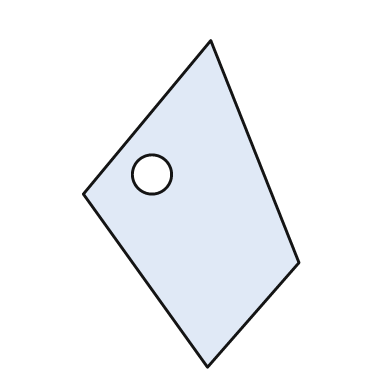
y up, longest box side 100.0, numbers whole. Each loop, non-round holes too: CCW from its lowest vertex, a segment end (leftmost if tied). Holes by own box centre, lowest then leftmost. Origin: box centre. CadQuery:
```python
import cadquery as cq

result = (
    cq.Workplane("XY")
    .moveTo(5.0, -50.0)
    .lineTo(33.0, -18.0)
    .lineTo(6.0, 50.0)
    .lineTo(-33.0, 3.0)
    .close()
    .moveTo(-12.0, 9.0)
    .circle(6.0)
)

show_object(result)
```